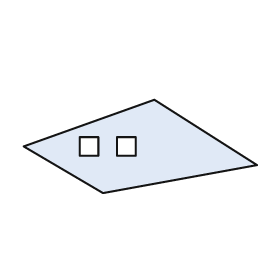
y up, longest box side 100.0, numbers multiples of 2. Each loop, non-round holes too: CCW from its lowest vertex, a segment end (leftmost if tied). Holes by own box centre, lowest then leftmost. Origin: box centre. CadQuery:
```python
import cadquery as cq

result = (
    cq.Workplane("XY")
    .moveTo(-16.0, -20.0)
    .lineTo(50.0, -8.0)
    .lineTo(6.0, 20.0)
    .lineTo(-50.0, 0.0)
    .close()
    .moveTo(-26.0, -4.0)
    .lineTo(-18.0, -4.0)
    .lineTo(-18.0, 4.0)
    .lineTo(-26.0, 4.0)
    .close()
    .moveTo(-10.0, -4.0)
    .lineTo(-2.0, -4.0)
    .lineTo(-2.0, 4.0)
    .lineTo(-10.0, 4.0)
    .close()
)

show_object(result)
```